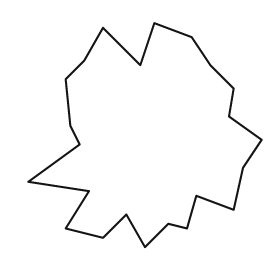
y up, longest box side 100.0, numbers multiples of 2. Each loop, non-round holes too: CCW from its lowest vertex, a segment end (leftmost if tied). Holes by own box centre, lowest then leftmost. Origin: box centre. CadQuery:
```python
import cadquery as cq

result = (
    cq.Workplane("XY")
    .moveTo(0.0, -48.0)
    .lineTo(10.0, -38.0)
    .lineTo(18.0, -40.0)
    .lineTo(22.0, -26.0)
    .lineTo(38.0, -32.0)
    .lineTo(42.0, -14.0)
    .lineTo(50.0, -2.0)
    .lineTo(36.0, 8.0)
    .lineTo(38.0, 20.0)
    .lineTo(28.0, 30.0)
    .lineTo(20.0, 42.0)
    .lineTo(4.0, 48.0)
    .lineTo(-2.0, 30.0)
    .lineTo(-18.0, 46.0)
    .lineTo(-26.0, 32.0)
    .lineTo(-34.0, 24.0)
    .lineTo(-32.0, 4.0)
    .lineTo(-28.0, -4.0)
    .lineTo(-50.0, -20.0)
    .lineTo(-24.0, -24.0)
    .lineTo(-34.0, -40.0)
    .lineTo(-18.0, -44.0)
    .lineTo(-8.0, -34.0)
    .close()
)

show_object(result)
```